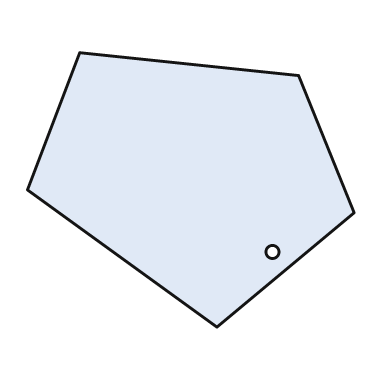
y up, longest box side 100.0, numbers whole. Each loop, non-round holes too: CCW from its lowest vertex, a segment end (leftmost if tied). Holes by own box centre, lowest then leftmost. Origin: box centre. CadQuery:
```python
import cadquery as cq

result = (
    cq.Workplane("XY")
    .moveTo(8.0, -42.0)
    .lineTo(50.0, -7.0)
    .lineTo(33.0, 35.0)
    .lineTo(-34.0, 42.0)
    .lineTo(-50.0, 0.0)
    .close()
    .moveTo(25.0, -19.0)
    .circle(2.0)
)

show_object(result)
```